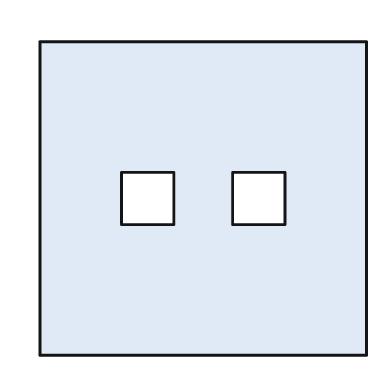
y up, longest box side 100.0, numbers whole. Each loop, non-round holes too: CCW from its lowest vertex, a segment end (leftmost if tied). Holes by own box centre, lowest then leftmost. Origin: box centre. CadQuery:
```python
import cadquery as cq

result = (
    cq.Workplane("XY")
    .moveTo(-50.0, -48.0)
    .lineTo(50.0, -48.0)
    .lineTo(50.0, 48.0)
    .lineTo(-50.0, 48.0)
    .close()
    .moveTo(-25.0, -8.0)
    .lineTo(-9.0, -8.0)
    .lineTo(-9.0, 8.0)
    .lineTo(-25.0, 8.0)
    .close()
    .moveTo(9.0, -8.0)
    .lineTo(25.0, -8.0)
    .lineTo(25.0, 8.0)
    .lineTo(9.0, 8.0)
    .close()
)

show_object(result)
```